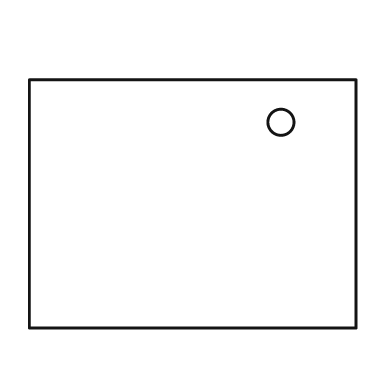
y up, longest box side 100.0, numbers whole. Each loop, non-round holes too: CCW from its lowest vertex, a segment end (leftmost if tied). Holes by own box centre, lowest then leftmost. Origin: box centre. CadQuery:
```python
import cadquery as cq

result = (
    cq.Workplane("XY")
    .moveTo(-50.0, -38.0)
    .lineTo(50.0, -38.0)
    .lineTo(50.0, 38.0)
    .lineTo(-50.0, 38.0)
    .close()
    .moveTo(27.0, 25.0)
    .circle(4.0)
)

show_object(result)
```